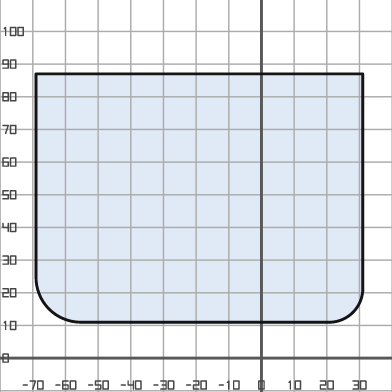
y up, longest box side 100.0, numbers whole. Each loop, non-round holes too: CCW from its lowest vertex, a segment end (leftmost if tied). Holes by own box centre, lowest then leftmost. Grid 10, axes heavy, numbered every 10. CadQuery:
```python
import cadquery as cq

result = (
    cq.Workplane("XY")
    .moveTo(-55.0, 11.0)
    .lineTo(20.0, 11.0)
    .threePointArc((28.0, 14.0), (31.0, 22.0))
    .lineTo(31.0, 87.0)
    .lineTo(-69.0, 87.0)
    .lineTo(-69.0, 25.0)
    .threePointArc((-65.0, 15.0), (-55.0, 11.0))
    .close()
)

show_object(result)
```